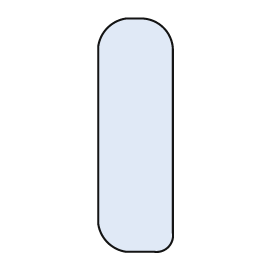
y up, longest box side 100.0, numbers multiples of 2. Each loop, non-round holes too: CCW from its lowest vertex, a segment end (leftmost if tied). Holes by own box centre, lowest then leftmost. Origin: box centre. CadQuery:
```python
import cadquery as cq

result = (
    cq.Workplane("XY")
    .moveTo(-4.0, -50.0)
    .lineTo(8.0, -50.0)
    .threePointArc((14.0, -48.0), (16.0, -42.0))
    .lineTo(16.0, 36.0)
    .threePointArc((12.0, 46.0), (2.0, 50.0))
    .lineTo(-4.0, 50.0)
    .threePointArc((-12.0, 46.0), (-16.0, 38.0))
    .lineTo(-16.0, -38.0)
    .threePointArc((-12.0, -46.0), (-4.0, -50.0))
    .close()
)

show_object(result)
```